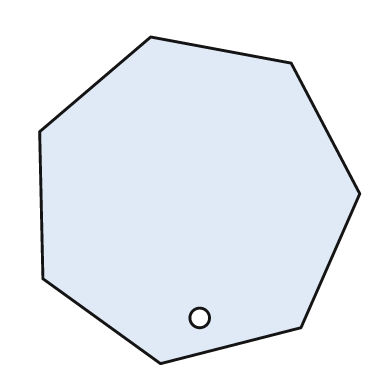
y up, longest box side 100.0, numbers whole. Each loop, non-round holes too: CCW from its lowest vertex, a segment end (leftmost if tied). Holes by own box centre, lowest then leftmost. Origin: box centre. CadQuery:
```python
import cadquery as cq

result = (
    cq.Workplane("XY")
    .moveTo(-12.0, -50.0)
    .lineTo(31.0, -39.0)
    .lineTo(49.0, 2.0)
    .lineTo(28.0, 42.0)
    .lineTo(-15.0, 50.0)
    .lineTo(-49.0, 21.0)
    .lineTo(-48.0, -24.0)
    .close()
    .moveTo(0.0, -36.0)
    .circle(3.0)
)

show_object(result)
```